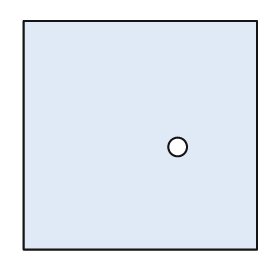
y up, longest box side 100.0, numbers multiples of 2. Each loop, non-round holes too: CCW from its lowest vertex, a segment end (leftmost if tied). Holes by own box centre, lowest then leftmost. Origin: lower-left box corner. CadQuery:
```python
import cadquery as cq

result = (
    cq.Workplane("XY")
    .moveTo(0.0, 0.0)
    .lineTo(100.0, 0.0)
    .lineTo(100.0, 98.0)
    .lineTo(0.0, 98.0)
    .close()
    .moveTo(66.0, 44.0)
    .circle(4.0)
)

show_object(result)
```